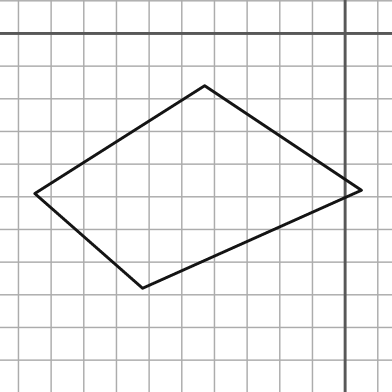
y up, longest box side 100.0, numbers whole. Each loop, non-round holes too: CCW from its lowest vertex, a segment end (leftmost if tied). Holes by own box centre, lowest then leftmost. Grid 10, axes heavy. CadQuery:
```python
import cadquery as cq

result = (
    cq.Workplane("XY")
    .moveTo(-62.0, -78.0)
    .lineTo(5.0, -48.0)
    .lineTo(-43.0, -16.0)
    .lineTo(-95.0, -49.0)
    .close()
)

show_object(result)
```